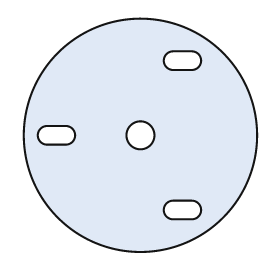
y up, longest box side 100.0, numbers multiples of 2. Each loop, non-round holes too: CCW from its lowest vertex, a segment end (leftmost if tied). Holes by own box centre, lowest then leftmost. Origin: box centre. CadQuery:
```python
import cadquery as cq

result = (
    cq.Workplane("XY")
    .moveTo(0.0, 0.0)
    .circle(50.0)
    .moveTo(14.0, -36.0)
    .lineTo(22.0, -36.0)
    .threePointArc((26.0, -32.0), (22.0, -28.0))
    .lineTo(14.0, -28.0)
    .threePointArc((10.0, -32.0), (14.0, -36.0))
    .close()
    .moveTo(-40.0, -4.0)
    .lineTo(-32.0, -4.0)
    .threePointArc((-28.0, 0.0), (-32.0, 4.0))
    .lineTo(-40.0, 4.0)
    .threePointArc((-44.0, 0.0), (-40.0, -4.0))
    .close()
    .moveTo(0.0, 0.0)
    .circle(6.0)
    .moveTo(14.0, 28.0)
    .lineTo(22.0, 28.0)
    .threePointArc((26.0, 32.0), (22.0, 36.0))
    .lineTo(14.0, 36.0)
    .threePointArc((10.0, 32.0), (14.0, 28.0))
    .close()
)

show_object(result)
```